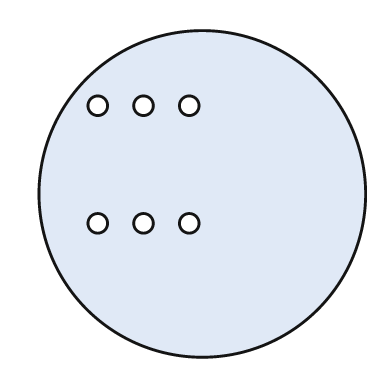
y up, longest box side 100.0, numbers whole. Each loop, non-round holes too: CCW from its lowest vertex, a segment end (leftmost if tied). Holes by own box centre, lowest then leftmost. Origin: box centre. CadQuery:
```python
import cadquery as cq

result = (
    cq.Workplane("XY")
    .moveTo(0.0, 0.0)
    .circle(50.0)
    .moveTo(-32.0, -9.0)
    .circle(3.0)
    .moveTo(-18.0, -9.0)
    .circle(3.0)
    .moveTo(-4.0, -9.0)
    .circle(3.0)
    .moveTo(-32.0, 27.0)
    .circle(3.0)
    .moveTo(-18.0, 27.0)
    .circle(3.0)
    .moveTo(-4.0, 27.0)
    .circle(3.0)
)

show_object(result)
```